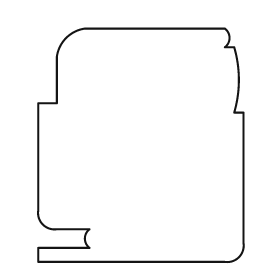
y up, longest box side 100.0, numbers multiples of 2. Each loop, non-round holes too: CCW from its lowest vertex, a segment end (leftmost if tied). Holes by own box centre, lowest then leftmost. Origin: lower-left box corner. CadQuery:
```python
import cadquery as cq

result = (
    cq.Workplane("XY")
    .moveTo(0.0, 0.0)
    .lineTo(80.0, 0.0)
    .threePointArc((86.0, 2.0), (88.0, 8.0))
    .lineTo(88.0, 64.0)
    .lineTo(84.0, 64.0)
    .threePointArc((86.0, 78.0), (84.0, 92.0))
    .lineTo(80.0, 92.0)
    .threePointArc((82.0, 96.0), (80.0, 100.0))
    .lineTo(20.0, 100.0)
    .threePointArc((12.0, 96.0), (8.0, 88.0))
    .lineTo(8.0, 68.0)
    .lineTo(0.0, 68.0)
    .lineTo(0.0, 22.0)
    .threePointArc((2.0, 16.0), (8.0, 14.0))
    .lineTo(22.0, 14.0)
    .threePointArc((20.0, 10.0), (22.0, 6.0))
    .lineTo(0.0, 6.0)
    .close()
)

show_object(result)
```